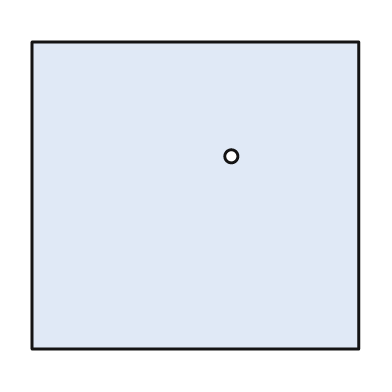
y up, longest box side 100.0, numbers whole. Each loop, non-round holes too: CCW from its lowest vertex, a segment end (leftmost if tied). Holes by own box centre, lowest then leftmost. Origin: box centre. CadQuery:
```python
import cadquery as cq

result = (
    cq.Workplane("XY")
    .moveTo(-50.0, -47.0)
    .lineTo(50.0, -47.0)
    .lineTo(50.0, 47.0)
    .lineTo(-50.0, 47.0)
    .close()
    .moveTo(11.0, 12.0)
    .circle(2.0)
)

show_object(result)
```